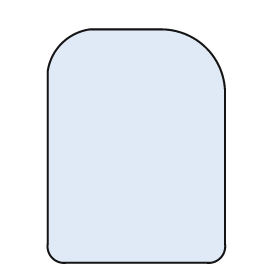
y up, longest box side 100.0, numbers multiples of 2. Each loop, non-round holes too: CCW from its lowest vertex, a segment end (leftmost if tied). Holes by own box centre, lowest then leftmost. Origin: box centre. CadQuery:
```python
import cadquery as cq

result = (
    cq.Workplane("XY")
    .moveTo(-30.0, -50.0)
    .lineTo(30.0, -50.0)
    .threePointArc((36.0, -48.0), (38.0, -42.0))
    .lineTo(38.0, 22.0)
    .threePointArc((30.0, 42.0), (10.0, 50.0))
    .lineTo(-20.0, 50.0)
    .threePointArc((-32.0, 44.0), (-38.0, 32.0))
    .lineTo(-38.0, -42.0)
    .threePointArc((-36.0, -48.0), (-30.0, -50.0))
    .close()
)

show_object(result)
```